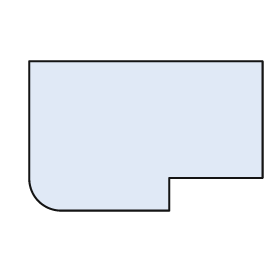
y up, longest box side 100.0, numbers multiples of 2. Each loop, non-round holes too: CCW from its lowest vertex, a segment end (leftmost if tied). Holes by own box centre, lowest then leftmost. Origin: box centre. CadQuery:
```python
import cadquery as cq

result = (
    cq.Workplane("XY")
    .moveTo(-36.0, -32.0)
    .lineTo(10.0, -32.0)
    .lineTo(10.0, -18.0)
    .lineTo(50.0, -18.0)
    .lineTo(50.0, 32.0)
    .lineTo(-50.0, 32.0)
    .lineTo(-50.0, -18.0)
    .threePointArc((-46.0, -28.0), (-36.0, -32.0))
    .close()
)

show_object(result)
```